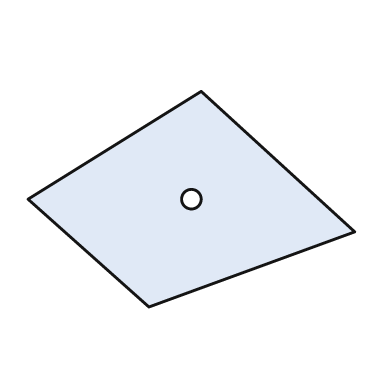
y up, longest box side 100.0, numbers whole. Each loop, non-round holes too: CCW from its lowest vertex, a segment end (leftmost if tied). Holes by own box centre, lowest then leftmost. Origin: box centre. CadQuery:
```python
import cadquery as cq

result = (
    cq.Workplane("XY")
    .moveTo(-13.0, -33.0)
    .lineTo(50.0, -10.0)
    .lineTo(3.0, 33.0)
    .lineTo(-50.0, 0.0)
    .close()
    .moveTo(0.0, 0.0)
    .circle(3.0)
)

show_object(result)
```